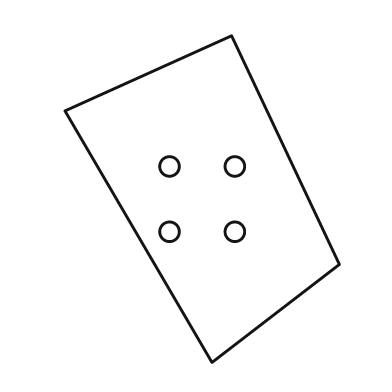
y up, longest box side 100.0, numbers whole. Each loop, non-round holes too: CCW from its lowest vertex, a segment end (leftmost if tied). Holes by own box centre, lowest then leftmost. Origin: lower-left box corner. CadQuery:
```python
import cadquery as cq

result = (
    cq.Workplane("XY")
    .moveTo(45.0, 0.0)
    .lineTo(84.0, 30.0)
    .lineTo(51.0, 100.0)
    .lineTo(0.0, 77.0)
    .close()
    .moveTo(32.0, 40.0)
    .circle(3.0)
    .moveTo(52.0, 40.0)
    .circle(3.0)
    .moveTo(32.0, 60.0)
    .circle(3.0)
    .moveTo(52.0, 60.0)
    .circle(3.0)
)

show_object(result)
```